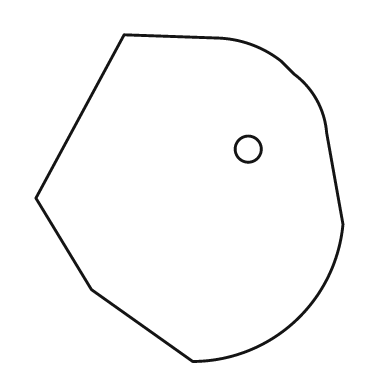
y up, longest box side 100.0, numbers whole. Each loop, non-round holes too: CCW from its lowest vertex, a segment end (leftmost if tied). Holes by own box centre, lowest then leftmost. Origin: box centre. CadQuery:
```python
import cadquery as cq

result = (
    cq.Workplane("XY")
    .moveTo(1.0, -50.0)
    .threePointArc((32.0, -38.0), (47.0, -8.0))
    .lineTo(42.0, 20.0)
    .threePointArc((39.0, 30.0), (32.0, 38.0))
    .lineTo(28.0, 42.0)
    .threePointArc((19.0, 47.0), (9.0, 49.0))
    .lineTo(-20.0, 50.0)
    .lineTo(-47.0, 0.0)
    .lineTo(-30.0, -28.0)
    .close()
    .moveTo(18.0, 15.0)
    .circle(4.0)
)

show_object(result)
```